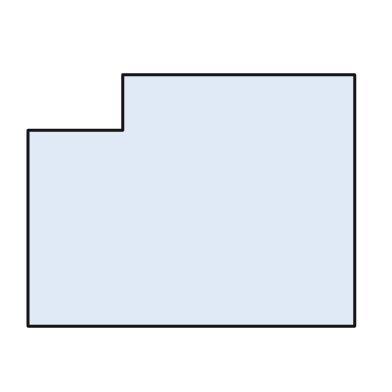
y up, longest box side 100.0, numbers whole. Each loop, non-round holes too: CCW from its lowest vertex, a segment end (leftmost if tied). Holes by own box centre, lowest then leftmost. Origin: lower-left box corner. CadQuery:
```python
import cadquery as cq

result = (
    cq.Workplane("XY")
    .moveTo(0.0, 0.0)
    .lineTo(100.0, 0.0)
    .lineTo(100.0, 77.0)
    .lineTo(29.0, 77.0)
    .lineTo(29.0, 60.0)
    .lineTo(0.0, 60.0)
    .close()
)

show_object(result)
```